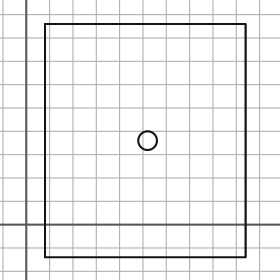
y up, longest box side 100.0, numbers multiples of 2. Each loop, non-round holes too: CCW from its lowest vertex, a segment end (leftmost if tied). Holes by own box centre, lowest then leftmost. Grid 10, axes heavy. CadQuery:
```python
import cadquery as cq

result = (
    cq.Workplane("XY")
    .moveTo(8.0, -14.0)
    .lineTo(94.0, -14.0)
    .lineTo(94.0, 86.0)
    .lineTo(8.0, 86.0)
    .close()
    .moveTo(52.0, 36.0)
    .circle(4.0)
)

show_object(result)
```